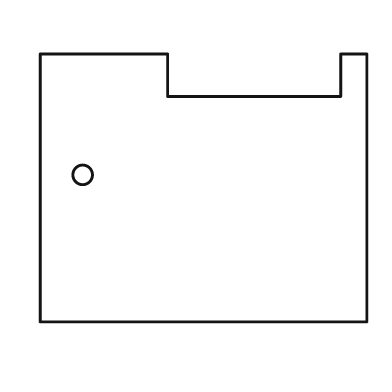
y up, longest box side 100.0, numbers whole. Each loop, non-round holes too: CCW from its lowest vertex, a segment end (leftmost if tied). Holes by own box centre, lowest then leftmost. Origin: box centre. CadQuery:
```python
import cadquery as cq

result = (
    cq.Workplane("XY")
    .moveTo(-50.0, -41.0)
    .lineTo(50.0, -41.0)
    .lineTo(50.0, 41.0)
    .lineTo(42.0, 41.0)
    .lineTo(42.0, 28.0)
    .lineTo(-11.0, 28.0)
    .lineTo(-11.0, 41.0)
    .lineTo(-50.0, 41.0)
    .close()
    .moveTo(-37.0, 4.0)
    .circle(3.0)
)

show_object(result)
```